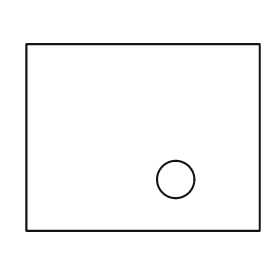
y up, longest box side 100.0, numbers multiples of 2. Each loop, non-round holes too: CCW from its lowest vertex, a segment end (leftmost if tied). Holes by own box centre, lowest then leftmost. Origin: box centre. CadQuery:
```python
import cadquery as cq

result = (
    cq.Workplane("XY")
    .moveTo(-50.0, -40.0)
    .lineTo(50.0, -40.0)
    .lineTo(50.0, 40.0)
    .lineTo(-50.0, 40.0)
    .close()
    .moveTo(14.0, -18.0)
    .circle(8.0)
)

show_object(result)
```